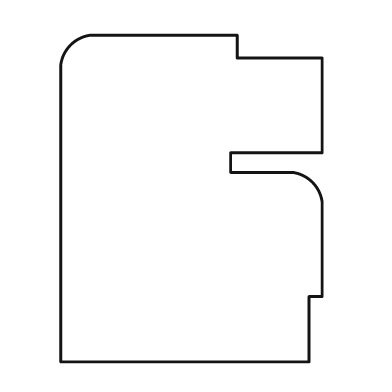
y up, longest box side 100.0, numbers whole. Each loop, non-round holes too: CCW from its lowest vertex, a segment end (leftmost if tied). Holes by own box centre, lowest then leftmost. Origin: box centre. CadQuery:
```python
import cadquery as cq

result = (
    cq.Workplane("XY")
    .moveTo(-40.0, -50.0)
    .lineTo(36.0, -50.0)
    .lineTo(36.0, -30.0)
    .lineTo(40.0, -30.0)
    .lineTo(40.0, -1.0)
    .threePointArc((37.0, 5.0), (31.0, 8.0))
    .lineTo(12.0, 8.0)
    .lineTo(12.0, 14.0)
    .lineTo(40.0, 14.0)
    .lineTo(40.0, 43.0)
    .lineTo(14.0, 43.0)
    .lineTo(14.0, 50.0)
    .lineTo(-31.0, 50.0)
    .threePointArc((-37.0, 47.0), (-40.0, 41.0))
    .close()
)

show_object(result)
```